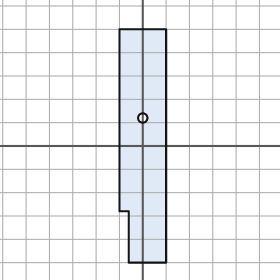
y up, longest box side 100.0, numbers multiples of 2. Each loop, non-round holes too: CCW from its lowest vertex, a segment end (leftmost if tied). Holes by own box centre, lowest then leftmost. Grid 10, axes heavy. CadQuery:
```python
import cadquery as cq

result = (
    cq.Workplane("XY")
    .moveTo(-6.0, -50.0)
    .lineTo(10.0, -50.0)
    .lineTo(10.0, 50.0)
    .lineTo(-10.0, 50.0)
    .lineTo(-10.0, -28.0)
    .lineTo(-6.0, -28.0)
    .close()
    .moveTo(0.0, 12.0)
    .circle(2.0)
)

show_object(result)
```